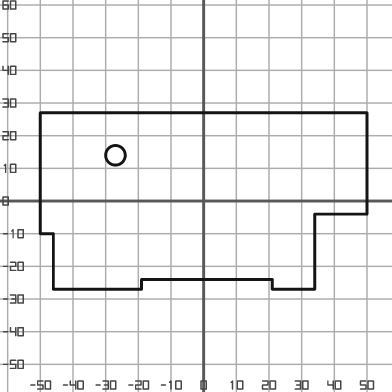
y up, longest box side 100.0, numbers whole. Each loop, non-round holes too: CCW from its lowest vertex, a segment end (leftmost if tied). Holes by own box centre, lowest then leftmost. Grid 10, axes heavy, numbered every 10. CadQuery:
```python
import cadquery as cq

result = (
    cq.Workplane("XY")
    .moveTo(-46.0, -27.0)
    .lineTo(-19.0, -27.0)
    .lineTo(-19.0, -24.0)
    .lineTo(21.0, -24.0)
    .lineTo(21.0, -27.0)
    .lineTo(34.0, -27.0)
    .lineTo(34.0, -4.0)
    .lineTo(50.0, -4.0)
    .lineTo(50.0, 27.0)
    .lineTo(-50.0, 27.0)
    .lineTo(-50.0, -10.0)
    .lineTo(-46.0, -10.0)
    .close()
    .moveTo(-27.0, 14.0)
    .circle(3.0)
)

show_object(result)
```